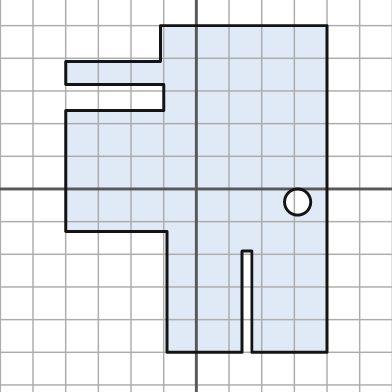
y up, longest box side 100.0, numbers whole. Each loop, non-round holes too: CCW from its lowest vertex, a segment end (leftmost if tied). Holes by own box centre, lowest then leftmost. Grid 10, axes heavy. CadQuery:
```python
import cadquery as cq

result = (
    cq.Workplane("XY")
    .moveTo(-9.0, -50.0)
    .lineTo(14.0, -50.0)
    .lineTo(14.0, -19.0)
    .lineTo(17.0, -19.0)
    .lineTo(17.0, -50.0)
    .lineTo(40.0, -50.0)
    .lineTo(40.0, 50.0)
    .lineTo(-11.0, 50.0)
    .lineTo(-11.0, 39.0)
    .lineTo(-40.0, 39.0)
    .lineTo(-40.0, 32.0)
    .lineTo(-10.0, 32.0)
    .lineTo(-10.0, 24.0)
    .lineTo(-40.0, 24.0)
    .lineTo(-40.0, -13.0)
    .lineTo(-9.0, -13.0)
    .close()
    .moveTo(31.0, -4.0)
    .circle(4.0)
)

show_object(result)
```